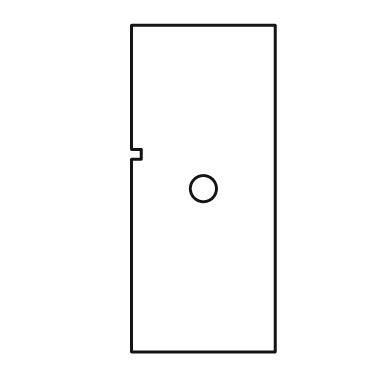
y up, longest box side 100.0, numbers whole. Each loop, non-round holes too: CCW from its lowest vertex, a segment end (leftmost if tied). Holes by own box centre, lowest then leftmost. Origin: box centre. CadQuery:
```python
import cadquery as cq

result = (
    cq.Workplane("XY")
    .moveTo(-22.0, -50.0)
    .lineTo(22.0, -50.0)
    .lineTo(22.0, 50.0)
    .lineTo(-22.0, 50.0)
    .lineTo(-22.0, 12.0)
    .lineTo(-19.0, 12.0)
    .lineTo(-19.0, 9.0)
    .lineTo(-22.0, 9.0)
    .close()
    .moveTo(0.0, 0.0)
    .circle(4.0)
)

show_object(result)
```